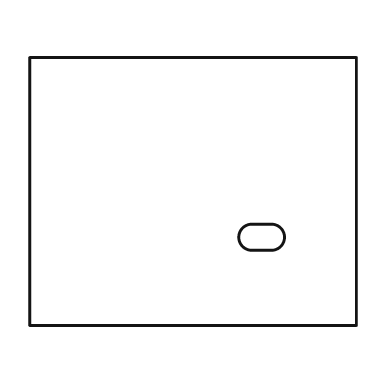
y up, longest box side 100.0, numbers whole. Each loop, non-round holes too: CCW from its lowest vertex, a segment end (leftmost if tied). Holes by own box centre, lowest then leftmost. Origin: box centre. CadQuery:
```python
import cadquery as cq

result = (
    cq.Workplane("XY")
    .moveTo(-50.0, -41.0)
    .lineTo(50.0, -41.0)
    .lineTo(50.0, 41.0)
    .lineTo(-50.0, 41.0)
    .close()
    .moveTo(18.0, -18.0)
    .lineTo(24.0, -18.0)
    .threePointArc((28.0, -14.0), (24.0, -10.0))
    .lineTo(18.0, -10.0)
    .threePointArc((14.0, -14.0), (18.0, -18.0))
    .close()
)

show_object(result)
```